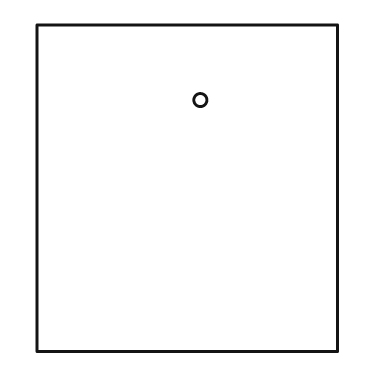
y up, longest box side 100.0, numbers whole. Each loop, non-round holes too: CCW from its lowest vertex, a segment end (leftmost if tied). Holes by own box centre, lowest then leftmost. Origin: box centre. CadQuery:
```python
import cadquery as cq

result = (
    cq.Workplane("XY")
    .moveTo(-46.0, -50.0)
    .lineTo(46.0, -50.0)
    .lineTo(46.0, 50.0)
    .lineTo(-46.0, 50.0)
    .close()
    .moveTo(4.0, 27.0)
    .circle(2.0)
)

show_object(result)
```